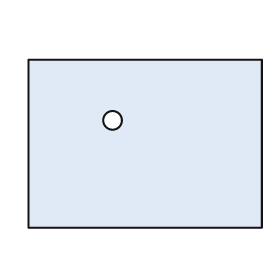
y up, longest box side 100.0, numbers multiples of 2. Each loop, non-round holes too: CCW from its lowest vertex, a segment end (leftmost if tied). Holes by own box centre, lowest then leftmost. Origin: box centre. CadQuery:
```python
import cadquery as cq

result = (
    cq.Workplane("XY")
    .moveTo(-50.0, -36.0)
    .lineTo(50.0, -36.0)
    .lineTo(50.0, 36.0)
    .lineTo(-50.0, 36.0)
    .close()
    .moveTo(-14.0, 10.0)
    .circle(4.0)
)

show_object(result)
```